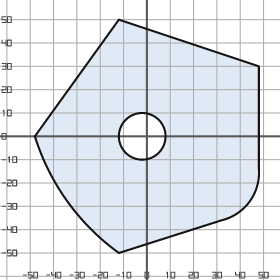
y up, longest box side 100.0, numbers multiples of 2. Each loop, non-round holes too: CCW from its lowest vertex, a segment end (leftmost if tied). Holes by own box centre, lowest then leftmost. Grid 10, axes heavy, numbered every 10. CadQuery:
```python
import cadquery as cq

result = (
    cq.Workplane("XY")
    .moveTo(-12.0, -50.0)
    .lineTo(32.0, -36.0)
    .threePointArc((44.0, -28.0), (48.0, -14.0))
    .lineTo(48.0, 30.0)
    .lineTo(-12.0, 50.0)
    .lineTo(-48.0, 0.0)
    .threePointArc((-34.0, -28.0), (-12.0, -50.0))
    .close()
    .moveTo(-2.0, 0.0)
    .circle(10.0)
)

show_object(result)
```